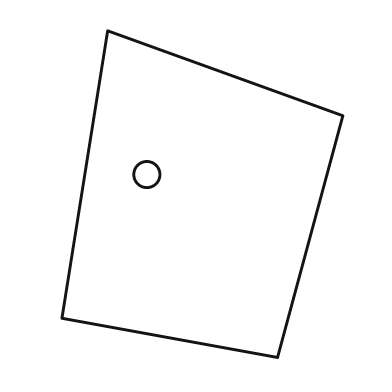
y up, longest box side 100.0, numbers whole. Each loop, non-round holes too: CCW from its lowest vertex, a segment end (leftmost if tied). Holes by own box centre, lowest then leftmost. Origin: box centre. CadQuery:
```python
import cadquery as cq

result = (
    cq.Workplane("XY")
    .moveTo(23.0, -50.0)
    .lineTo(43.0, 24.0)
    .lineTo(-29.0, 50.0)
    .lineTo(-43.0, -38.0)
    .close()
    .moveTo(-17.0, 6.0)
    .circle(4.0)
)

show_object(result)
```